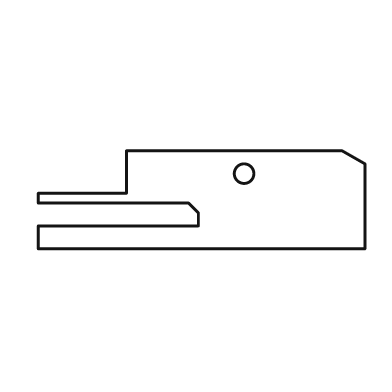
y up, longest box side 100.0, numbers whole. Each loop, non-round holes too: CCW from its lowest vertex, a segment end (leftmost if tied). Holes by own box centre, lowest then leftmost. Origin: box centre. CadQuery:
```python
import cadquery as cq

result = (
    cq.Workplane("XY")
    .moveTo(-50.0, -15.0)
    .lineTo(50.0, -15.0)
    .lineTo(50.0, 11.0)
    .lineTo(43.0, 15.0)
    .lineTo(-23.0, 15.0)
    .lineTo(-23.0, 2.0)
    .lineTo(-50.0, 2.0)
    .lineTo(-50.0, -1.0)
    .lineTo(-4.0, -1.0)
    .lineTo(-1.0, -4.0)
    .lineTo(-1.0, -8.0)
    .lineTo(-50.0, -8.0)
    .close()
    .moveTo(13.0, 8.0)
    .circle(3.0)
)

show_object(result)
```